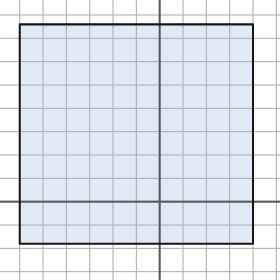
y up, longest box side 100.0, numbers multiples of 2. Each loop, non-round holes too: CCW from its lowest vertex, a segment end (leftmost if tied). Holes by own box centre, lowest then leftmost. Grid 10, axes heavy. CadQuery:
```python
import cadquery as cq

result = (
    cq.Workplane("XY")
    .moveTo(-60.0, -18.0)
    .lineTo(40.0, -18.0)
    .lineTo(40.0, 76.0)
    .lineTo(-60.0, 76.0)
    .close()
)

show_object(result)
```